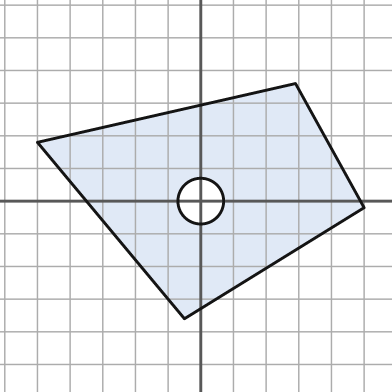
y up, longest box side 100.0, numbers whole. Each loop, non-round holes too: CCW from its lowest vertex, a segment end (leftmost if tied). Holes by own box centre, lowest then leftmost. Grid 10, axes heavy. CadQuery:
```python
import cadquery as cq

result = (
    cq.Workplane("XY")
    .moveTo(-5.0, -36.0)
    .lineTo(50.0, -2.0)
    .lineTo(29.0, 36.0)
    .lineTo(-50.0, 18.0)
    .close()
    .moveTo(0.0, 0.0)
    .circle(7.0)
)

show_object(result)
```